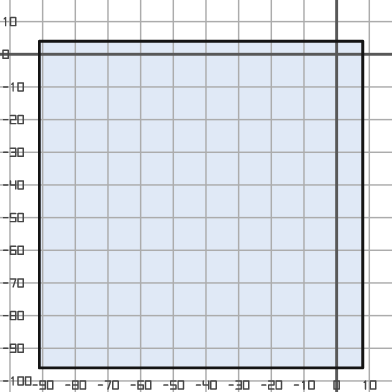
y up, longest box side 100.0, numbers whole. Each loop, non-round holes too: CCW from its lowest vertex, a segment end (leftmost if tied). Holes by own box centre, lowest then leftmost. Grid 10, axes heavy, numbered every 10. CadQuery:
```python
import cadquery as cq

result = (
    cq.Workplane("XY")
    .moveTo(-91.0, -96.0)
    .lineTo(8.0, -96.0)
    .lineTo(8.0, 4.0)
    .lineTo(-91.0, 4.0)
    .close()
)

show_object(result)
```